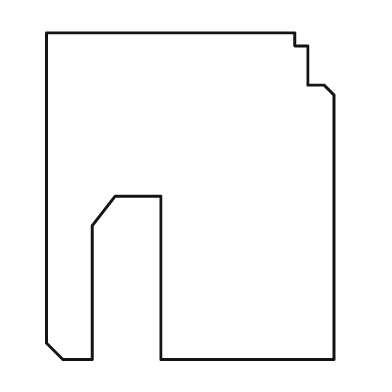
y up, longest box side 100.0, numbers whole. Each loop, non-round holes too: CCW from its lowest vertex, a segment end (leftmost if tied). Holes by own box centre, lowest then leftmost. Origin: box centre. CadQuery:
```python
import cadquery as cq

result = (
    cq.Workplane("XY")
    .moveTo(-39.0, -50.0)
    .lineTo(-30.0, -50.0)
    .lineTo(-30.0, -9.0)
    .lineTo(-23.0, 0.0)
    .lineTo(-9.0, 0.0)
    .lineTo(-9.0, -50.0)
    .lineTo(44.0, -50.0)
    .lineTo(44.0, 31.0)
    .lineTo(41.0, 34.0)
    .lineTo(36.0, 34.0)
    .lineTo(36.0, 46.0)
    .lineTo(32.0, 46.0)
    .lineTo(32.0, 50.0)
    .lineTo(-44.0, 50.0)
    .lineTo(-44.0, -45.0)
    .close()
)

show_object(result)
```